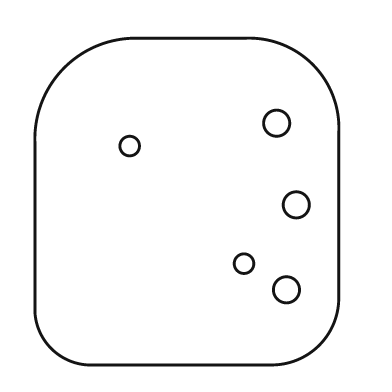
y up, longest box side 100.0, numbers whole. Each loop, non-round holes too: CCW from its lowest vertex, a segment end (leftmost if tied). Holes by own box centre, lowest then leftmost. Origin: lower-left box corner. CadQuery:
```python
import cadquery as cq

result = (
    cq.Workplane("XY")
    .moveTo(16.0, 0.0)
    .lineTo(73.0, 0.0)
    .threePointArc((87.0, 6.0), (93.0, 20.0))
    .lineTo(93.0, 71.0)
    .threePointArc((85.0, 92.0), (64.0, 100.0))
    .lineTo(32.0, 100.0)
    .threePointArc((9.0, 91.0), (0.0, 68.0))
    .lineTo(0.0, 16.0)
    .threePointArc((5.0, 5.0), (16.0, 0.0))
    .close()
    .moveTo(77.0, 23.0)
    .circle(4.0)
    .moveTo(64.0, 31.0)
    .circle(3.0)
    .moveTo(80.0, 49.0)
    .circle(4.0)
    .moveTo(29.0, 67.0)
    .circle(3.0)
    .moveTo(74.0, 74.0)
    .circle(4.0)
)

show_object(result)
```